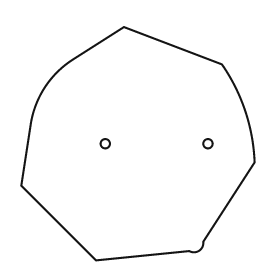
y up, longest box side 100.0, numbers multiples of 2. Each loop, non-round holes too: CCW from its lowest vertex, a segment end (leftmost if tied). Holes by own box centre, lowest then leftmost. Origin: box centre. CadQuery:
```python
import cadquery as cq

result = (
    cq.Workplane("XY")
    .moveTo(-18.0, -50.0)
    .lineTo(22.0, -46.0)
    .threePointArc((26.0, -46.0), (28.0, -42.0))
    .lineTo(50.0, -8.0)
    .threePointArc((46.0, 14.0), (36.0, 34.0))
    .lineTo(-6.0, 50.0)
    .lineTo(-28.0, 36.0)
    .threePointArc((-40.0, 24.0), (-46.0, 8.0))
    .lineTo(-50.0, -18.0)
    .close()
    .moveTo(-14.0, 0.0)
    .circle(2.0)
    .moveTo(30.0, 0.0)
    .circle(2.0)
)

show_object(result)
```